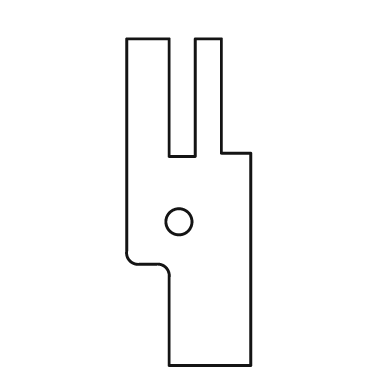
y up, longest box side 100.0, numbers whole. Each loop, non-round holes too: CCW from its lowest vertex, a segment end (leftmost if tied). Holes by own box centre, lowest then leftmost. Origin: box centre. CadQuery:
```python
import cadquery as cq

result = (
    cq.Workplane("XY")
    .moveTo(-6.0, -50.0)
    .lineTo(19.0, -50.0)
    .lineTo(19.0, 15.0)
    .lineTo(10.0, 15.0)
    .lineTo(10.0, 50.0)
    .lineTo(2.0, 50.0)
    .lineTo(2.0, 14.0)
    .lineTo(-6.0, 14.0)
    .lineTo(-6.0, 50.0)
    .lineTo(-19.0, 50.0)
    .lineTo(-19.0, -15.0)
    .threePointArc((-18.0, -18.0), (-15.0, -19.0))
    .lineTo(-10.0, -19.0)
    .threePointArc((-7.0, -20.0), (-6.0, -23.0))
    .close()
    .moveTo(-3.0, -6.0)
    .circle(4.0)
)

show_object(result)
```